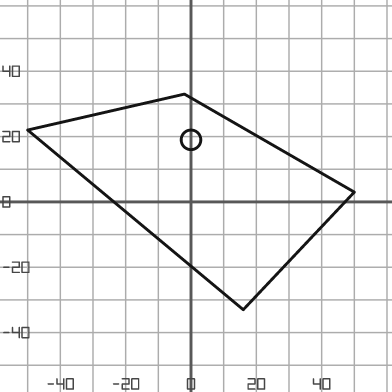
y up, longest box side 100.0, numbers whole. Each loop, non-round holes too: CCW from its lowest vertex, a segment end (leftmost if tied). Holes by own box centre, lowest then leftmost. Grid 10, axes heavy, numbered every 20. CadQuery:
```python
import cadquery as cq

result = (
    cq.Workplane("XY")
    .moveTo(16.0, -33.0)
    .lineTo(50.0, 3.0)
    .lineTo(-2.0, 33.0)
    .lineTo(-50.0, 22.0)
    .close()
    .moveTo(0.0, 19.0)
    .circle(3.0)
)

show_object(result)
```